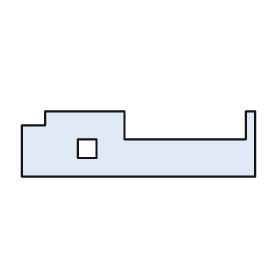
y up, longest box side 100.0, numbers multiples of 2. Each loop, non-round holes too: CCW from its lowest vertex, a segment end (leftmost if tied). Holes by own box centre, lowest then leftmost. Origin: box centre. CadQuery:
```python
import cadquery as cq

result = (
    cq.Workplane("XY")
    .moveTo(-50.0, -14.0)
    .lineTo(50.0, -14.0)
    .lineTo(50.0, 14.0)
    .lineTo(46.0, 14.0)
    .lineTo(46.0, 2.0)
    .lineTo(-6.0, 2.0)
    .lineTo(-6.0, 14.0)
    .lineTo(-40.0, 14.0)
    .lineTo(-40.0, 8.0)
    .lineTo(-50.0, 8.0)
    .close()
    .moveTo(-26.0, -6.0)
    .lineTo(-18.0, -6.0)
    .lineTo(-18.0, 2.0)
    .lineTo(-26.0, 2.0)
    .close()
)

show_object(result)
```